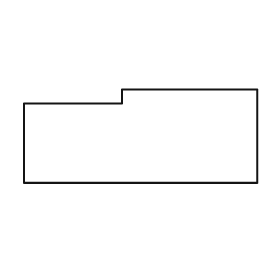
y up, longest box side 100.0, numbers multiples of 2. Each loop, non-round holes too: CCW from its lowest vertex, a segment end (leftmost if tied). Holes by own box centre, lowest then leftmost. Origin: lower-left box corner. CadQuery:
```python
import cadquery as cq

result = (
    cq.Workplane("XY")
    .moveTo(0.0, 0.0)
    .lineTo(100.0, 0.0)
    .lineTo(100.0, 40.0)
    .lineTo(42.0, 40.0)
    .lineTo(42.0, 34.0)
    .lineTo(0.0, 34.0)
    .close()
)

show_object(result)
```